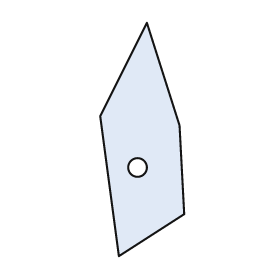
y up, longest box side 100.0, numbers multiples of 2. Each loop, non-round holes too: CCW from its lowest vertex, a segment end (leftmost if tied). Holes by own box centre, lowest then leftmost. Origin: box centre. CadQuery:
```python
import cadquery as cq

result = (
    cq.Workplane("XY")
    .moveTo(-10.0, -50.0)
    .lineTo(18.0, -32.0)
    .lineTo(16.0, 6.0)
    .lineTo(2.0, 50.0)
    .lineTo(-18.0, 10.0)
    .close()
    .moveTo(-2.0, -12.0)
    .circle(4.0)
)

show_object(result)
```